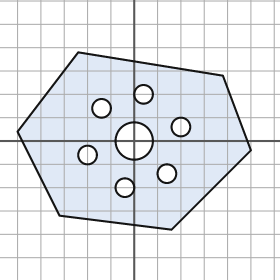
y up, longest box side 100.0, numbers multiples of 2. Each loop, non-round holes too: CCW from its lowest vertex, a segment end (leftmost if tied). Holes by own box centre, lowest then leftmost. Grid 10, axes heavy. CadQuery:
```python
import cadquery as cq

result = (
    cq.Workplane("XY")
    .moveTo(16.0, -38.0)
    .lineTo(50.0, -4.0)
    .lineTo(38.0, 28.0)
    .lineTo(-24.0, 38.0)
    .lineTo(-50.0, 4.0)
    .lineTo(-32.0, -32.0)
    .close()
    .moveTo(-4.0, -20.0)
    .circle(4.0)
    .moveTo(14.0, -14.0)
    .circle(4.0)
    .moveTo(-20.0, -6.0)
    .circle(4.0)
    .moveTo(0.0, 0.0)
    .circle(8.0)
    .moveTo(20.0, 6.0)
    .circle(4.0)
    .moveTo(-14.0, 14.0)
    .circle(4.0)
    .moveTo(4.0, 20.0)
    .circle(4.0)
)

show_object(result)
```